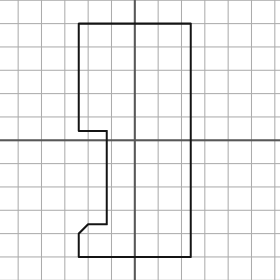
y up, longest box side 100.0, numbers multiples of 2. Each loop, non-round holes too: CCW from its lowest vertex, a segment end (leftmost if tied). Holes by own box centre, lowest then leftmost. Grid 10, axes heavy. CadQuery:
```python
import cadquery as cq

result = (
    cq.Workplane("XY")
    .moveTo(-24.0, -50.0)
    .lineTo(24.0, -50.0)
    .lineTo(24.0, 50.0)
    .lineTo(-24.0, 50.0)
    .lineTo(-24.0, 4.0)
    .lineTo(-12.0, 4.0)
    .lineTo(-12.0, -36.0)
    .lineTo(-20.0, -36.0)
    .lineTo(-24.0, -40.0)
    .close()
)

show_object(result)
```